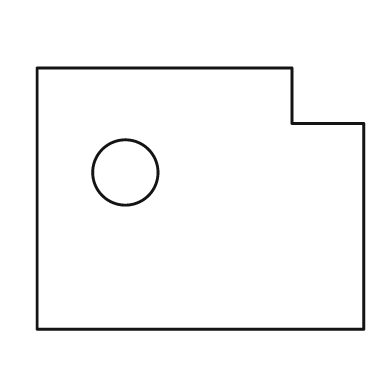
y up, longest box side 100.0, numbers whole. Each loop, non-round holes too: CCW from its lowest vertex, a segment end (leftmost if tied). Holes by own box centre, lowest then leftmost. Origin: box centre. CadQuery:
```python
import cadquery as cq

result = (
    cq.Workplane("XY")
    .moveTo(-50.0, -40.0)
    .lineTo(50.0, -40.0)
    .lineTo(50.0, 23.0)
    .lineTo(28.0, 23.0)
    .lineTo(28.0, 40.0)
    .lineTo(-50.0, 40.0)
    .close()
    .moveTo(-23.0, 8.0)
    .circle(10.0)
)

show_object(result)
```